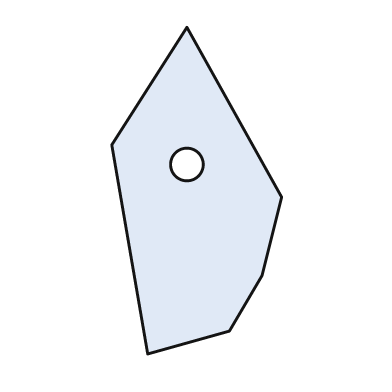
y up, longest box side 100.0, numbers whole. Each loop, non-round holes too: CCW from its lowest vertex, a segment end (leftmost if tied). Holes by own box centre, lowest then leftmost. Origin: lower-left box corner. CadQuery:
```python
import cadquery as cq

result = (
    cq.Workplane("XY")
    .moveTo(11.0, 0.0)
    .lineTo(36.0, 7.0)
    .lineTo(46.0, 24.0)
    .lineTo(52.0, 48.0)
    .lineTo(23.0, 100.0)
    .lineTo(0.0, 64.0)
    .close()
    .moveTo(23.0, 58.0)
    .circle(5.0)
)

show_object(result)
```